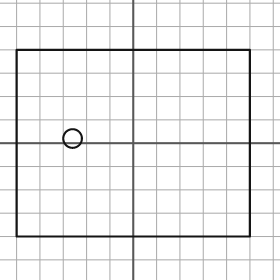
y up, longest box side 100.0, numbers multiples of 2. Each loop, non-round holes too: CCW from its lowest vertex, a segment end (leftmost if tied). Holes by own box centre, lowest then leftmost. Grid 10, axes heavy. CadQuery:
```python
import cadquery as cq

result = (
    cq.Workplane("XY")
    .moveTo(-50.0, -40.0)
    .lineTo(50.0, -40.0)
    .lineTo(50.0, 40.0)
    .lineTo(-50.0, 40.0)
    .close()
    .moveTo(-26.0, 2.0)
    .circle(4.0)
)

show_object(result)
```